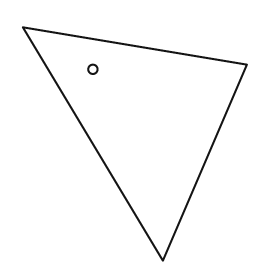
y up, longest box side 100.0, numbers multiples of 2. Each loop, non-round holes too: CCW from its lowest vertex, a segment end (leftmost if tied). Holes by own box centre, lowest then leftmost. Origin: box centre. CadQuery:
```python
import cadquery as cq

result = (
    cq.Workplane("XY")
    .moveTo(12.0, -50.0)
    .lineTo(48.0, 34.0)
    .lineTo(-48.0, 50.0)
    .close()
    .moveTo(-18.0, 32.0)
    .circle(2.0)
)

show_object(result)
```